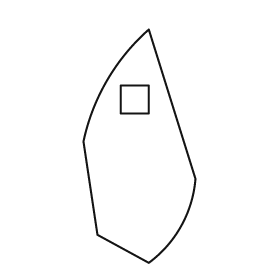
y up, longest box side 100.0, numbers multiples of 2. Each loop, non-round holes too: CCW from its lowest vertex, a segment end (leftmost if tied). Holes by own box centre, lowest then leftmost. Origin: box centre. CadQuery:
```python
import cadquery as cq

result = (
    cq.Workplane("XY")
    .moveTo(4.0, -50.0)
    .threePointArc((18.0, -34.0), (24.0, -14.0))
    .lineTo(4.0, 50.0)
    .threePointArc((-14.0, 28.0), (-24.0, 2.0))
    .lineTo(-18.0, -38.0)
    .close()
    .moveTo(-8.0, 14.0)
    .lineTo(4.0, 14.0)
    .lineTo(4.0, 26.0)
    .lineTo(-8.0, 26.0)
    .close()
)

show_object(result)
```